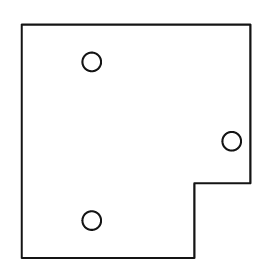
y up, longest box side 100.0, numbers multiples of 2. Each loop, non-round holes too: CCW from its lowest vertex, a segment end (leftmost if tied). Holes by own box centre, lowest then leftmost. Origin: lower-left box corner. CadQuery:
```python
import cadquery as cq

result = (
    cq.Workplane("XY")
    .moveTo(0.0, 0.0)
    .lineTo(74.0, 0.0)
    .lineTo(74.0, 32.0)
    .lineTo(98.0, 32.0)
    .lineTo(98.0, 100.0)
    .lineTo(0.0, 100.0)
    .close()
    .moveTo(30.0, 16.0)
    .circle(4.0)
    .moveTo(90.0, 50.0)
    .circle(4.0)
    .moveTo(30.0, 84.0)
    .circle(4.0)
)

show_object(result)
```